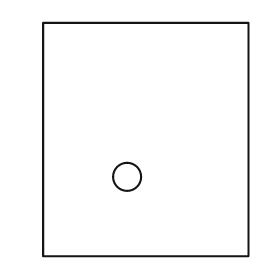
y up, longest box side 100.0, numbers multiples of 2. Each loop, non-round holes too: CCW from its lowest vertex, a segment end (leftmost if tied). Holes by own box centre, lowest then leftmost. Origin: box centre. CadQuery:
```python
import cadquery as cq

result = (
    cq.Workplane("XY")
    .moveTo(-44.0, -50.0)
    .lineTo(44.0, -50.0)
    .lineTo(44.0, 50.0)
    .lineTo(-44.0, 50.0)
    .close()
    .moveTo(-8.0, -16.0)
    .circle(6.0)
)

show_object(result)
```